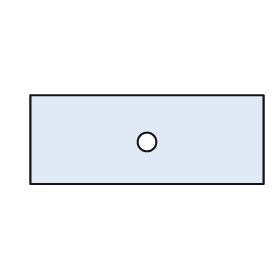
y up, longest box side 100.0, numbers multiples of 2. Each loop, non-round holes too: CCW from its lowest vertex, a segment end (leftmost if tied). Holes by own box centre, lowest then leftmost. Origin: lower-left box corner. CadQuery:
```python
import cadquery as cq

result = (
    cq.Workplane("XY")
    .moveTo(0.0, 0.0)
    .lineTo(100.0, 0.0)
    .lineTo(100.0, 38.0)
    .lineTo(0.0, 38.0)
    .close()
    .moveTo(50.0, 18.0)
    .circle(4.0)
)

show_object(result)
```